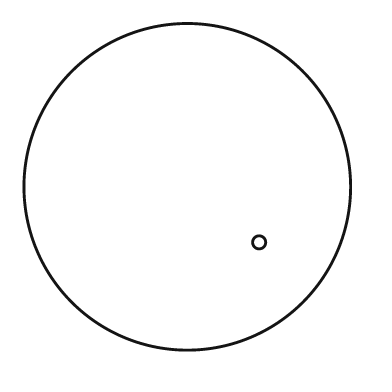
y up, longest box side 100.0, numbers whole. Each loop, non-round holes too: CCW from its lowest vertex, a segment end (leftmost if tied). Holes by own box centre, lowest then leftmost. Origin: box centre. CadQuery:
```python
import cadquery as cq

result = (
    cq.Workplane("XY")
    .moveTo(0.0, 0.0)
    .circle(50.0)
    .moveTo(22.0, -17.0)
    .circle(2.0)
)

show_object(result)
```